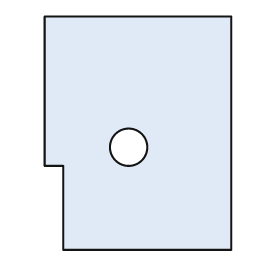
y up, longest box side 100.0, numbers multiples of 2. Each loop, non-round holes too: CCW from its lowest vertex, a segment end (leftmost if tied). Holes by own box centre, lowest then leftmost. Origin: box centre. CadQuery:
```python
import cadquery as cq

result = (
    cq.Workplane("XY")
    .moveTo(-32.0, -50.0)
    .lineTo(40.0, -50.0)
    .lineTo(40.0, 50.0)
    .lineTo(-40.0, 50.0)
    .lineTo(-40.0, -14.0)
    .lineTo(-32.0, -14.0)
    .close()
    .moveTo(-4.0, -6.0)
    .circle(8.0)
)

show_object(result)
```